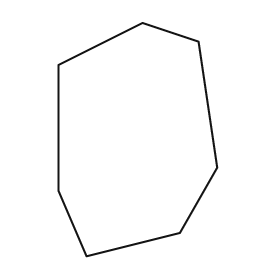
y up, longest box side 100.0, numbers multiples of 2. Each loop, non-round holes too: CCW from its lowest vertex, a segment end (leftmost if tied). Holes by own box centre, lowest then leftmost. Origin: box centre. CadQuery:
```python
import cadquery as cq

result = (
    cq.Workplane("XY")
    .moveTo(-22.0, -50.0)
    .lineTo(18.0, -40.0)
    .lineTo(34.0, -12.0)
    .lineTo(26.0, 42.0)
    .lineTo(2.0, 50.0)
    .lineTo(-34.0, 32.0)
    .lineTo(-34.0, -22.0)
    .close()
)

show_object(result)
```